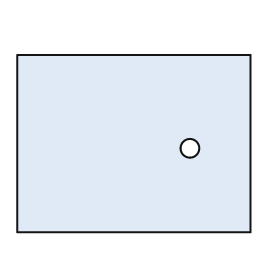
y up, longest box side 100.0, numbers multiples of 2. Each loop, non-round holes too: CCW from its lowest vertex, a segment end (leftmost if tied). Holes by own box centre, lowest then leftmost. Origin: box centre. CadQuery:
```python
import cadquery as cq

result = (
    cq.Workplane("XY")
    .moveTo(-50.0, -38.0)
    .lineTo(50.0, -38.0)
    .lineTo(50.0, 38.0)
    .lineTo(-50.0, 38.0)
    .close()
    .moveTo(24.0, -2.0)
    .circle(4.0)
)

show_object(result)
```